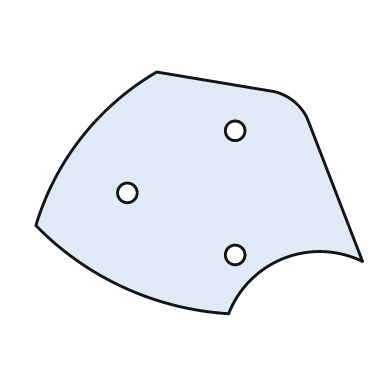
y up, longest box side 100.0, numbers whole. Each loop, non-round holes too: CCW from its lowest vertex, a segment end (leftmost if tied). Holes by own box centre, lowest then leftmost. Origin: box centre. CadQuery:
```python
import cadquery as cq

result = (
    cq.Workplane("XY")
    .moveTo(9.0, -37.0)
    .threePointArc((26.0, -20.0), (50.0, -21.0))
    .lineTo(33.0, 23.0)
    .threePointArc((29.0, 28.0), (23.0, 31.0))
    .lineTo(-13.0, 37.0)
    .threePointArc((-36.0, 17.0), (-50.0, -10.0))
    .threePointArc((-23.0, -29.0), (9.0, -37.0))
    .close()
    .moveTo(11.0, -19.0)
    .circle(3.0)
    .moveTo(-22.0, 0.0)
    .circle(3.0)
    .moveTo(11.0, 19.0)
    .circle(3.0)
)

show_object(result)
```